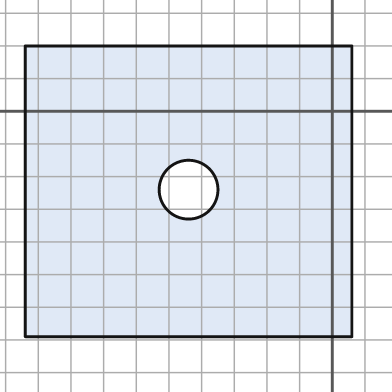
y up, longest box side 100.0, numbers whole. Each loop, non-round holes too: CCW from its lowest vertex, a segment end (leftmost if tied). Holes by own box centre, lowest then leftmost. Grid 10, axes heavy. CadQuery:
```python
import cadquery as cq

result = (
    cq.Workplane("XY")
    .moveTo(-94.0, -69.0)
    .lineTo(6.0, -69.0)
    .lineTo(6.0, 20.0)
    .lineTo(-94.0, 20.0)
    .close()
    .moveTo(-44.0, -24.0)
    .circle(9.0)
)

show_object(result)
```